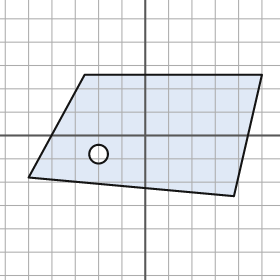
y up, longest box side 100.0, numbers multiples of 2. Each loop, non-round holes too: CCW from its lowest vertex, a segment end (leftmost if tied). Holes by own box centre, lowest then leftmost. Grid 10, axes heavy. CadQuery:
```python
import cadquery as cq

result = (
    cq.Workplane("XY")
    .moveTo(38.0, -26.0)
    .lineTo(50.0, 26.0)
    .lineTo(-26.0, 26.0)
    .lineTo(-50.0, -18.0)
    .close()
    .moveTo(-20.0, -8.0)
    .circle(4.0)
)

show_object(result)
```